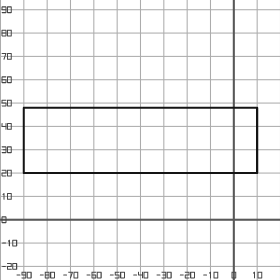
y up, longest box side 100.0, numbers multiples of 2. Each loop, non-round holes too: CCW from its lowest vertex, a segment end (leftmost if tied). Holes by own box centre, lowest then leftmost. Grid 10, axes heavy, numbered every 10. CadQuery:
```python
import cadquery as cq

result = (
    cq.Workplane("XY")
    .moveTo(-90.0, 20.0)
    .lineTo(10.0, 20.0)
    .lineTo(10.0, 48.0)
    .lineTo(-90.0, 48.0)
    .close()
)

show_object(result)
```